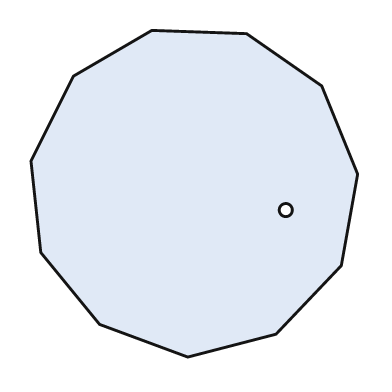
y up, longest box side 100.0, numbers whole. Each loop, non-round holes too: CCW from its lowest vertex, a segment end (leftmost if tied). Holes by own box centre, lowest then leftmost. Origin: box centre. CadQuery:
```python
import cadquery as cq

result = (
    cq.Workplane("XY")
    .moveTo(-2.0, -50.0)
    .lineTo(25.0, -43.0)
    .lineTo(45.0, -22.0)
    .lineTo(50.0, 6.0)
    .lineTo(39.0, 33.0)
    .lineTo(16.0, 49.0)
    .lineTo(-13.0, 50.0)
    .lineTo(-37.0, 36.0)
    .lineTo(-50.0, 10.0)
    .lineTo(-47.0, -18.0)
    .lineTo(-29.0, -40.0)
    .close()
    .moveTo(28.0, -5.0)
    .circle(2.0)
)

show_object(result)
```